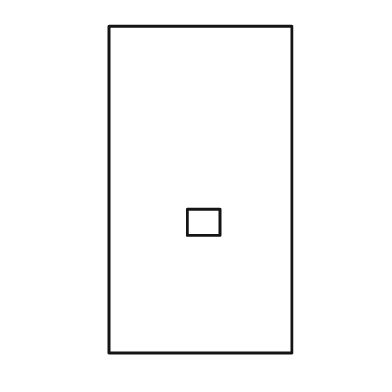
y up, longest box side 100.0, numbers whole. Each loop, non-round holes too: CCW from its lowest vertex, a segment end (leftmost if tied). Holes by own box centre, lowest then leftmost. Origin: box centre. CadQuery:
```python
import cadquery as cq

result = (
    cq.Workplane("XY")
    .moveTo(-28.0, -50.0)
    .lineTo(28.0, -50.0)
    .lineTo(28.0, 50.0)
    .lineTo(-28.0, 50.0)
    .close()
    .moveTo(-4.0, -14.0)
    .lineTo(6.0, -14.0)
    .lineTo(6.0, -6.0)
    .lineTo(-4.0, -6.0)
    .close()
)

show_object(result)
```